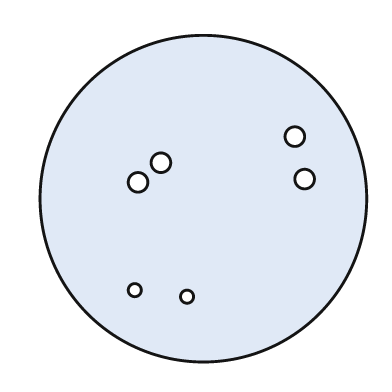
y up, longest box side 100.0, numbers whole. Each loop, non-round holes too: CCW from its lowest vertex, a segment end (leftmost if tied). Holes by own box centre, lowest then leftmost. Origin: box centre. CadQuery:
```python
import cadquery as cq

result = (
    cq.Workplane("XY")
    .moveTo(0.0, 0.0)
    .circle(50.0)
    .moveTo(-5.0, -30.0)
    .circle(2.0)
    .moveTo(-21.0, -28.0)
    .circle(2.0)
    .moveTo(-20.0, 5.0)
    .circle(3.0)
    .moveTo(31.0, 6.0)
    .circle(3.0)
    .moveTo(-13.0, 11.0)
    .circle(3.0)
    .moveTo(28.0, 19.0)
    .circle(3.0)
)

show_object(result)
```